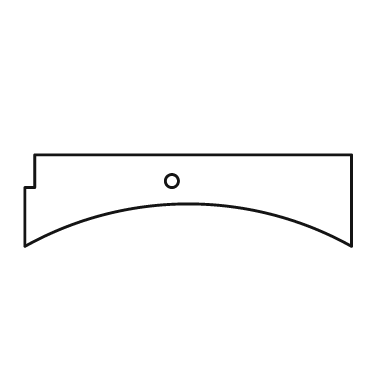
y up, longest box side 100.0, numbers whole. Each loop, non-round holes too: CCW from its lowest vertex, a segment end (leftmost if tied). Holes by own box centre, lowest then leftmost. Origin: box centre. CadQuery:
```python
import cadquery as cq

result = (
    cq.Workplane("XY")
    .moveTo(-50.0, -14.0)
    .threePointArc((0.0, -1.0), (50.0, -14.0))
    .lineTo(50.0, 14.0)
    .lineTo(-47.0, 14.0)
    .lineTo(-47.0, 4.0)
    .lineTo(-50.0, 4.0)
    .close()
    .moveTo(-5.0, 6.0)
    .circle(2.0)
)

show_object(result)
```